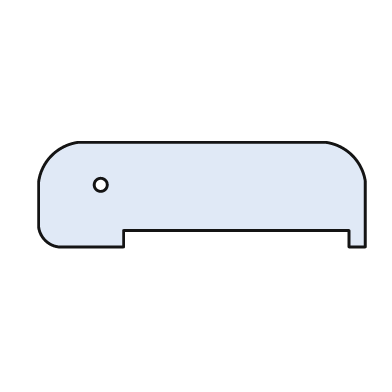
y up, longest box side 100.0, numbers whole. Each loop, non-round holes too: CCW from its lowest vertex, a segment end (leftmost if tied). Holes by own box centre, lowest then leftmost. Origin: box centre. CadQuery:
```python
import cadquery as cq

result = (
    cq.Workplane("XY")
    .moveTo(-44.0, -16.0)
    .lineTo(-24.0, -16.0)
    .lineTo(-24.0, -11.0)
    .lineTo(45.0, -11.0)
    .lineTo(45.0, -16.0)
    .lineTo(50.0, -16.0)
    .lineTo(50.0, 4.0)
    .threePointArc((46.0, 12.0), (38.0, 16.0))
    .lineTo(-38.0, 16.0)
    .threePointArc((-46.0, 12.0), (-50.0, 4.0))
    .lineTo(-50.0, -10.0)
    .threePointArc((-48.0, -14.0), (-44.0, -16.0))
    .close()
    .moveTo(-31.0, 3.0)
    .circle(2.0)
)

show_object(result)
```